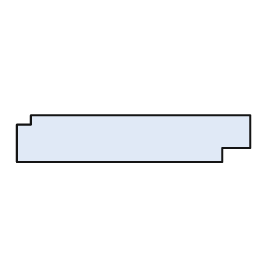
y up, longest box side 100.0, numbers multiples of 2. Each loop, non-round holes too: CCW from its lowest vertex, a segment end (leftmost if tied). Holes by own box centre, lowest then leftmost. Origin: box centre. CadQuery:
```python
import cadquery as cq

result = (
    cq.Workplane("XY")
    .moveTo(-50.0, -10.0)
    .lineTo(38.0, -10.0)
    .lineTo(38.0, -4.0)
    .lineTo(50.0, -4.0)
    .lineTo(50.0, 10.0)
    .lineTo(-44.0, 10.0)
    .lineTo(-44.0, 6.0)
    .lineTo(-50.0, 6.0)
    .close()
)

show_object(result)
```